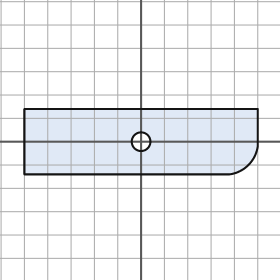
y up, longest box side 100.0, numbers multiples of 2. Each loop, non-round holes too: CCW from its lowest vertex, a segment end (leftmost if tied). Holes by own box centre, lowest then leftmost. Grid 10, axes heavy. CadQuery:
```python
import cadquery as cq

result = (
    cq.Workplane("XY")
    .moveTo(-50.0, -14.0)
    .lineTo(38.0, -14.0)
    .threePointArc((46.0, -10.0), (50.0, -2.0))
    .lineTo(50.0, 14.0)
    .lineTo(-50.0, 14.0)
    .close()
    .moveTo(0.0, 0.0)
    .circle(4.0)
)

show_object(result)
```